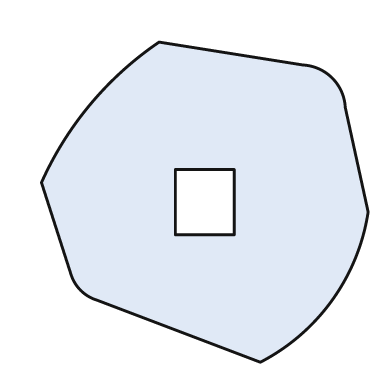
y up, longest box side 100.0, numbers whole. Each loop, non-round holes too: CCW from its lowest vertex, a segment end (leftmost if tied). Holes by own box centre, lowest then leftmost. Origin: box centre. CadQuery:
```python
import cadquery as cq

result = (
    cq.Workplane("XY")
    .moveTo(17.0, -49.0)
    .threePointArc((39.0, -30.0), (50.0, -3.0))
    .lineTo(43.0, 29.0)
    .threePointArc((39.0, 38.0), (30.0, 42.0))
    .lineTo(-14.0, 49.0)
    .threePointArc((-35.0, 30.0), (-50.0, 6.0))
    .lineTo(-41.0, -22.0)
    .threePointArc((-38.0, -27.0), (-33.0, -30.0))
    .close()
    .moveTo(-9.0, -10.0)
    .lineTo(9.0, -10.0)
    .lineTo(9.0, 10.0)
    .lineTo(-9.0, 10.0)
    .close()
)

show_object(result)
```